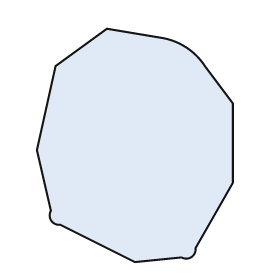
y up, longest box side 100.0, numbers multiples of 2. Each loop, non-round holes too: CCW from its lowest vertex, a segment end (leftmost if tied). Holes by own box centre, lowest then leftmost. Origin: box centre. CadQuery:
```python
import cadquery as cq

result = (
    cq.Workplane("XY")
    .moveTo(0.0, -50.0)
    .lineTo(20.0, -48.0)
    .threePointArc((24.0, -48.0), (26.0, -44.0))
    .lineTo(42.0, -16.0)
    .lineTo(42.0, 18.0)
    .lineTo(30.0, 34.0)
    .threePointArc((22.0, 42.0), (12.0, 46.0))
    .lineTo(-12.0, 50.0)
    .lineTo(-34.0, 34.0)
    .lineTo(-42.0, -2.0)
    .lineTo(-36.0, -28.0)
    .threePointArc((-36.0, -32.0), (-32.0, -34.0))
    .close()
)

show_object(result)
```